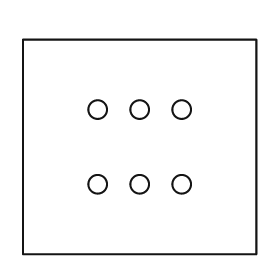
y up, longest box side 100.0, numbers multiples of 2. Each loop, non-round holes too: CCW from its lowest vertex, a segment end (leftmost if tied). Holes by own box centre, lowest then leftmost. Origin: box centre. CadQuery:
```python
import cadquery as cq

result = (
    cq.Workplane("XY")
    .moveTo(-50.0, -46.0)
    .lineTo(50.0, -46.0)
    .lineTo(50.0, 46.0)
    .lineTo(-50.0, 46.0)
    .close()
    .moveTo(-18.0, -16.0)
    .circle(4.0)
    .moveTo(0.0, -16.0)
    .circle(4.0)
    .moveTo(18.0, -16.0)
    .circle(4.0)
    .moveTo(-18.0, 16.0)
    .circle(4.0)
    .moveTo(0.0, 16.0)
    .circle(4.0)
    .moveTo(18.0, 16.0)
    .circle(4.0)
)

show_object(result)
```